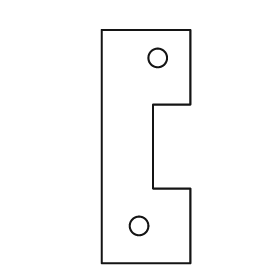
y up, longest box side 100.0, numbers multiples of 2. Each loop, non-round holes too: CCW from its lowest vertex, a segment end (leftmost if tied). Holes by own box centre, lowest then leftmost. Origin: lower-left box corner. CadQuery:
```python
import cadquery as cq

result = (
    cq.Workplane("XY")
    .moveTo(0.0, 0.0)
    .lineTo(38.0, 0.0)
    .lineTo(38.0, 32.0)
    .lineTo(22.0, 32.0)
    .lineTo(22.0, 68.0)
    .lineTo(38.0, 68.0)
    .lineTo(38.0, 100.0)
    .lineTo(0.0, 100.0)
    .close()
    .moveTo(16.0, 16.0)
    .circle(4.0)
    .moveTo(24.0, 88.0)
    .circle(4.0)
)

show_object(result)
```